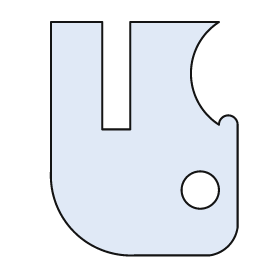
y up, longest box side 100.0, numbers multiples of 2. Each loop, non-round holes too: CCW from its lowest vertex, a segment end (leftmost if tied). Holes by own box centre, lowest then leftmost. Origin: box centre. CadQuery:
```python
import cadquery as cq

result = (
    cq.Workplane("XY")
    .moveTo(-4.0, -50.0)
    .lineTo(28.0, -50.0)
    .threePointArc((36.0, -46.0), (40.0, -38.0))
    .lineTo(40.0, 6.0)
    .threePointArc((36.0, 10.0), (32.0, 6.0))
    .threePointArc((20.0, 28.0), (32.0, 50.0))
    .lineTo(-6.0, 50.0)
    .lineTo(-6.0, 4.0)
    .lineTo(-18.0, 4.0)
    .lineTo(-18.0, 50.0)
    .lineTo(-40.0, 50.0)
    .lineTo(-40.0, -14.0)
    .threePointArc((-30.0, -40.0), (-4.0, -50.0))
    .close()
    .moveTo(24.0, -22.0)
    .circle(8.0)
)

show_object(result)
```